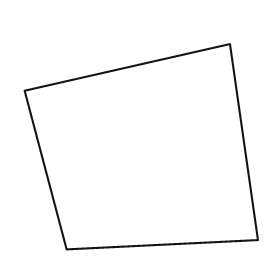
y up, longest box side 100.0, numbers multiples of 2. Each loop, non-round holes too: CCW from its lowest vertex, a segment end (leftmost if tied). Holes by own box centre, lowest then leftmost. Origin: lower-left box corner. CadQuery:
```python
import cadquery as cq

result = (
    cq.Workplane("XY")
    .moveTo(18.0, 0.0)
    .lineTo(100.0, 4.0)
    .lineTo(88.0, 88.0)
    .lineTo(0.0, 68.0)
    .close()
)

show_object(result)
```